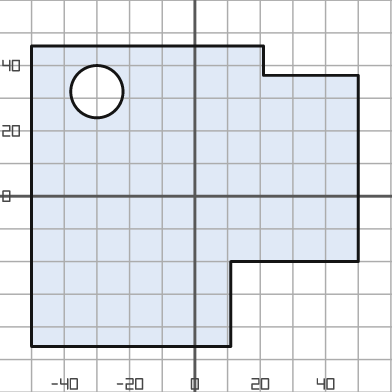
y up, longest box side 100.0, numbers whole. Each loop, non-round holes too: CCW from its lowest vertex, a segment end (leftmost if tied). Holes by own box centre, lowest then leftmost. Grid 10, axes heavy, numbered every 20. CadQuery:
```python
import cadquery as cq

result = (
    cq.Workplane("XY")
    .moveTo(-50.0, -46.0)
    .lineTo(11.0, -46.0)
    .lineTo(11.0, -20.0)
    .lineTo(50.0, -20.0)
    .lineTo(50.0, 37.0)
    .lineTo(21.0, 37.0)
    .lineTo(21.0, 46.0)
    .lineTo(-50.0, 46.0)
    .close()
    .moveTo(-30.0, 32.0)
    .circle(8.0)
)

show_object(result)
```